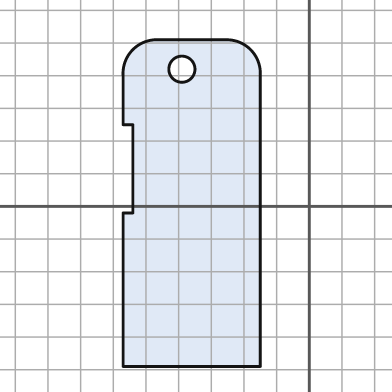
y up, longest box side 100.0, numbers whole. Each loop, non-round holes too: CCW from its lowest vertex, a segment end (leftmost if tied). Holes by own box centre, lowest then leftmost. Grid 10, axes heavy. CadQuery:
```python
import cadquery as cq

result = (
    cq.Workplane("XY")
    .moveTo(-57.0, -49.0)
    .lineTo(-15.0, -49.0)
    .lineTo(-15.0, 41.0)
    .threePointArc((-18.0, 48.0), (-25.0, 51.0))
    .lineTo(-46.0, 51.0)
    .threePointArc((-54.0, 48.0), (-57.0, 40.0))
    .lineTo(-57.0, 25.0)
    .lineTo(-54.0, 25.0)
    .lineTo(-54.0, -2.0)
    .lineTo(-57.0, -2.0)
    .close()
    .moveTo(-39.0, 42.0)
    .circle(4.0)
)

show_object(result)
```